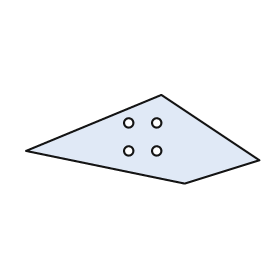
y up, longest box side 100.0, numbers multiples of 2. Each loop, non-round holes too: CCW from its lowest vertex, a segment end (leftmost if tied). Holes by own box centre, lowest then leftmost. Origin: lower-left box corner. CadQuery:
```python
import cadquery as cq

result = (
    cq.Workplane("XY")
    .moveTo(68.0, 0.0)
    .lineTo(100.0, 10.0)
    .lineTo(58.0, 38.0)
    .lineTo(0.0, 14.0)
    .close()
    .moveTo(44.0, 14.0)
    .circle(2.0)
    .moveTo(56.0, 14.0)
    .circle(2.0)
    .moveTo(44.0, 26.0)
    .circle(2.0)
    .moveTo(56.0, 26.0)
    .circle(2.0)
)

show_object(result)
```